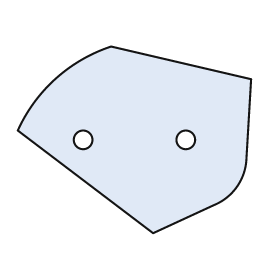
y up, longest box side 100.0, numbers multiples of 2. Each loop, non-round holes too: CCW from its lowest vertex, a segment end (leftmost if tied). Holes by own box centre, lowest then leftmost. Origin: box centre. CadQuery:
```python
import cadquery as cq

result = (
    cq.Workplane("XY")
    .moveTo(8.0, -40.0)
    .lineTo(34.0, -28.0)
    .threePointArc((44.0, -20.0), (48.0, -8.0))
    .lineTo(50.0, 26.0)
    .lineTo(-10.0, 40.0)
    .threePointArc((-34.0, 26.0), (-50.0, 4.0))
    .close()
    .moveTo(-22.0, 0.0)
    .circle(4.0)
    .moveTo(22.0, 0.0)
    .circle(4.0)
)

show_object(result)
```